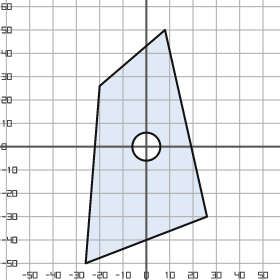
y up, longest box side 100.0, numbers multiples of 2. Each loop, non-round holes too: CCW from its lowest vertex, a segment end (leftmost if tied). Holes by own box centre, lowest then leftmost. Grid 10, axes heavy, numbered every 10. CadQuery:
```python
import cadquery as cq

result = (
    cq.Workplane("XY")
    .moveTo(-26.0, -50.0)
    .lineTo(26.0, -30.0)
    .lineTo(8.0, 50.0)
    .lineTo(-20.0, 26.0)
    .close()
    .moveTo(0.0, 0.0)
    .circle(6.0)
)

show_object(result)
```